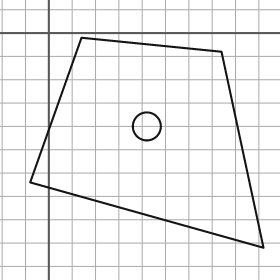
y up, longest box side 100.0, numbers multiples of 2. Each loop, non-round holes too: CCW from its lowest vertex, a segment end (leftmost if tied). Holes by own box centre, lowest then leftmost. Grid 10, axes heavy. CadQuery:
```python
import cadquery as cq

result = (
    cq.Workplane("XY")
    .moveTo(92.0, -92.0)
    .lineTo(74.0, -8.0)
    .lineTo(14.0, -2.0)
    .lineTo(-8.0, -64.0)
    .close()
    .moveTo(42.0, -40.0)
    .circle(6.0)
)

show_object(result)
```